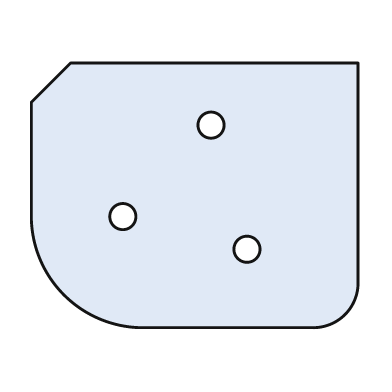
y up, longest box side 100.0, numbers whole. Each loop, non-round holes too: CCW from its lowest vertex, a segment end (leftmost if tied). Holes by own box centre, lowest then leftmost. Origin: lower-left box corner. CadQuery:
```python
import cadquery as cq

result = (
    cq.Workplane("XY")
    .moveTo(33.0, 0.0)
    .lineTo(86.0, 0.0)
    .threePointArc((96.0, 4.0), (100.0, 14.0))
    .lineTo(100.0, 81.0)
    .lineTo(12.0, 81.0)
    .lineTo(0.0, 69.0)
    .lineTo(0.0, 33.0)
    .threePointArc((10.0, 10.0), (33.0, 0.0))
    .close()
    .moveTo(66.0, 24.0)
    .circle(4.0)
    .moveTo(28.0, 34.0)
    .circle(4.0)
    .moveTo(55.0, 62.0)
    .circle(4.0)
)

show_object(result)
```